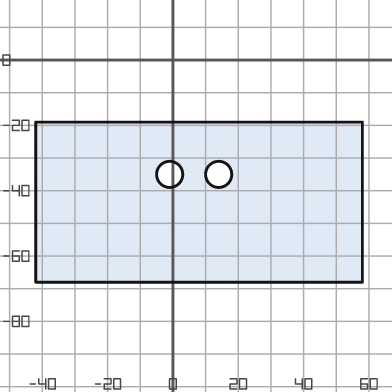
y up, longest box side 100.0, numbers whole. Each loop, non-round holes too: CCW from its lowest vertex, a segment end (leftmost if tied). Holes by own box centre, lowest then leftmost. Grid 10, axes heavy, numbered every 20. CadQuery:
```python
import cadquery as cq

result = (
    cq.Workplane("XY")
    .moveTo(-42.0, -68.0)
    .lineTo(58.0, -68.0)
    .lineTo(58.0, -19.0)
    .lineTo(-42.0, -19.0)
    .close()
    .moveTo(-1.0, -35.0)
    .circle(4.0)
    .moveTo(14.0, -35.0)
    .circle(4.0)
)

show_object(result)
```